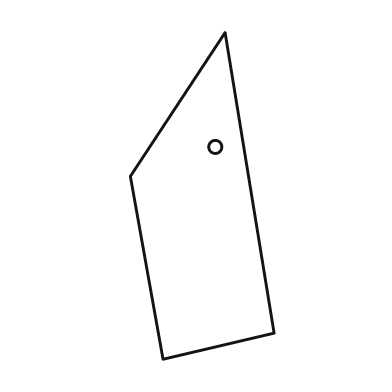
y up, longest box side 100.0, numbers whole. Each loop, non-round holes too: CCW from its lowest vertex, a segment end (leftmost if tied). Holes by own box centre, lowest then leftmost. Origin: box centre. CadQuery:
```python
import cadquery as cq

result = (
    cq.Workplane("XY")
    .moveTo(-12.0, -50.0)
    .lineTo(22.0, -42.0)
    .lineTo(7.0, 50.0)
    .lineTo(-22.0, 6.0)
    .close()
    .moveTo(4.0, 15.0)
    .circle(2.0)
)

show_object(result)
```